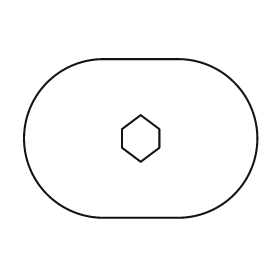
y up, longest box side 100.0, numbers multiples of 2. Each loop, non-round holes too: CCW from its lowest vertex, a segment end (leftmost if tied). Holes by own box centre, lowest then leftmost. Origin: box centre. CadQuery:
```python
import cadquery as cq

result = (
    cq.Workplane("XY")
    .moveTo(-16.0, -34.0)
    .lineTo(16.0, -34.0)
    .threePointArc((50.0, 0.0), (16.0, 34.0))
    .lineTo(-16.0, 34.0)
    .threePointArc((-50.0, 0.0), (-16.0, -34.0))
    .close()
    .moveTo(0.0, -10.0)
    .lineTo(8.0, -4.0)
    .lineTo(8.0, 4.0)
    .lineTo(0.0, 10.0)
    .lineTo(-8.0, 4.0)
    .lineTo(-8.0, -4.0)
    .close()
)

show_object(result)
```